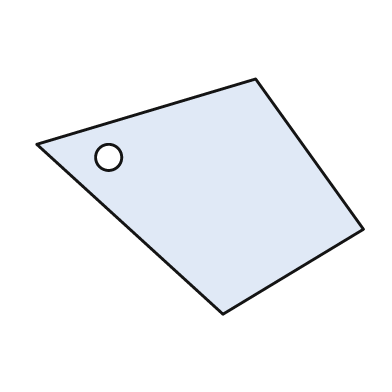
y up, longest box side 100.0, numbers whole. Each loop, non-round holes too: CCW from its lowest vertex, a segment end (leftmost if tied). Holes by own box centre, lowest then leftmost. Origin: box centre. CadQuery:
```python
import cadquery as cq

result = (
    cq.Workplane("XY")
    .moveTo(7.0, -36.0)
    .lineTo(50.0, -10.0)
    .lineTo(17.0, 36.0)
    .lineTo(-50.0, 16.0)
    .close()
    .moveTo(-28.0, 12.0)
    .circle(4.0)
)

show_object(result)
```